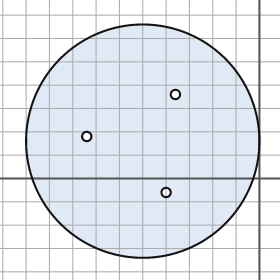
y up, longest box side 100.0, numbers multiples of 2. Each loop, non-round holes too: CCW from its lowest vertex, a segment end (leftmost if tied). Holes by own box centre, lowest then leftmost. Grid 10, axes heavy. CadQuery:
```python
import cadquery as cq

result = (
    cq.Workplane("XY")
    .moveTo(-50.0, 16.0)
    .circle(50.0)
    .moveTo(-40.0, -6.0)
    .circle(2.0)
    .moveTo(-74.0, 18.0)
    .circle(2.0)
    .moveTo(-36.0, 36.0)
    .circle(2.0)
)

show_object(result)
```